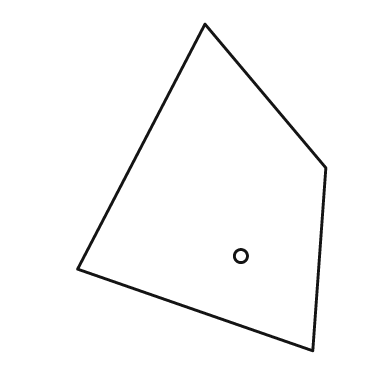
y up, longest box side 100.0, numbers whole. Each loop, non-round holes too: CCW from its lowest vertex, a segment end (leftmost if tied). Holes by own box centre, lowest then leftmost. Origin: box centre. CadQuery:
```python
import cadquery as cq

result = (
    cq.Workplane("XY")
    .moveTo(34.0, -50.0)
    .lineTo(38.0, 6.0)
    .lineTo(1.0, 50.0)
    .lineTo(-38.0, -25.0)
    .close()
    .moveTo(12.0, -21.0)
    .circle(2.0)
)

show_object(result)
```